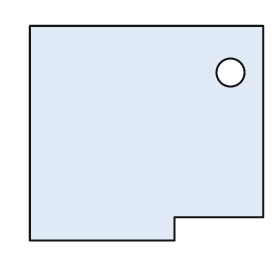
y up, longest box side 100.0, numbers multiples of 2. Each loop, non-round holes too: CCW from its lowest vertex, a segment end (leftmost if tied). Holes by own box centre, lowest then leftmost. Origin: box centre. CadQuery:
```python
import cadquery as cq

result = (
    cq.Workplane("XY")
    .moveTo(-50.0, -46.0)
    .lineTo(12.0, -46.0)
    .lineTo(12.0, -36.0)
    .lineTo(50.0, -36.0)
    .lineTo(50.0, 46.0)
    .lineTo(-50.0, 46.0)
    .close()
    .moveTo(36.0, 26.0)
    .circle(6.0)
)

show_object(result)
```